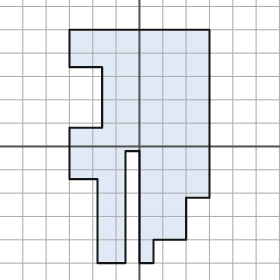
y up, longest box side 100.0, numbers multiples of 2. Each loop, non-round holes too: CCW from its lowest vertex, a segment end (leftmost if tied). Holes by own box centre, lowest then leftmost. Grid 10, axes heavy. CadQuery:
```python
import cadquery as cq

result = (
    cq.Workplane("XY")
    .moveTo(-18.0, -50.0)
    .lineTo(-6.0, -50.0)
    .lineTo(-6.0, -2.0)
    .lineTo(0.0, -2.0)
    .lineTo(0.0, -50.0)
    .lineTo(6.0, -50.0)
    .lineTo(6.0, -40.0)
    .lineTo(20.0, -40.0)
    .lineTo(20.0, -22.0)
    .lineTo(30.0, -22.0)
    .lineTo(30.0, 50.0)
    .lineTo(-30.0, 50.0)
    .lineTo(-30.0, 34.0)
    .lineTo(-16.0, 34.0)
    .lineTo(-16.0, 8.0)
    .lineTo(-30.0, 8.0)
    .lineTo(-30.0, -14.0)
    .lineTo(-18.0, -14.0)
    .close()
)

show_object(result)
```